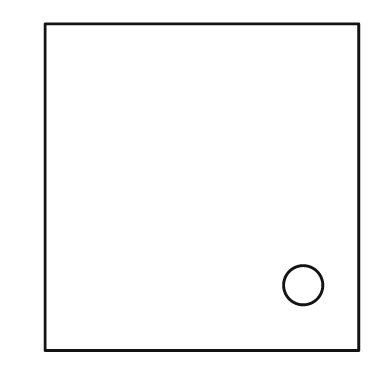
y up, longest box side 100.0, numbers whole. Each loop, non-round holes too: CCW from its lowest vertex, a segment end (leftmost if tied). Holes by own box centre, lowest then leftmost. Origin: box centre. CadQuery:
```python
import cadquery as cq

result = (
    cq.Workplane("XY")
    .moveTo(-48.0, -50.0)
    .lineTo(48.0, -50.0)
    .lineTo(48.0, 50.0)
    .lineTo(-48.0, 50.0)
    .close()
    .moveTo(31.0, -30.0)
    .circle(6.0)
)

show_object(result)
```